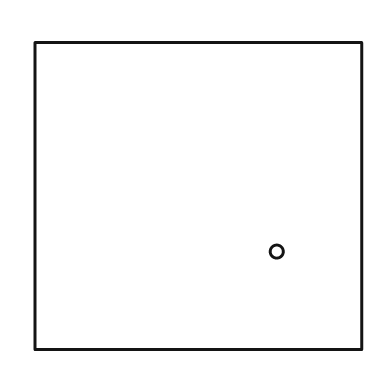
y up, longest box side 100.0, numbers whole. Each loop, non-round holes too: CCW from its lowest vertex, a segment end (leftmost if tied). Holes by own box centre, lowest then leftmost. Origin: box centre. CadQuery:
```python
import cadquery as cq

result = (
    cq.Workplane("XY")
    .moveTo(-50.0, -47.0)
    .lineTo(50.0, -47.0)
    .lineTo(50.0, 47.0)
    .lineTo(-50.0, 47.0)
    .close()
    .moveTo(24.0, -17.0)
    .circle(2.0)
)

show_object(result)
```